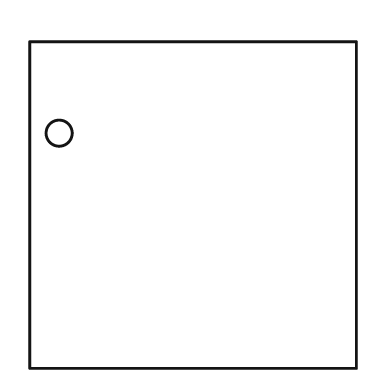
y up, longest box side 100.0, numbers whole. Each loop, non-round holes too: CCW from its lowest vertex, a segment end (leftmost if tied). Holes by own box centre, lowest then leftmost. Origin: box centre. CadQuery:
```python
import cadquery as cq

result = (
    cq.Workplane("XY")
    .moveTo(-50.0, -50.0)
    .lineTo(50.0, -50.0)
    .lineTo(50.0, 50.0)
    .lineTo(-50.0, 50.0)
    .close()
    .moveTo(-41.0, 22.0)
    .circle(4.0)
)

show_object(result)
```